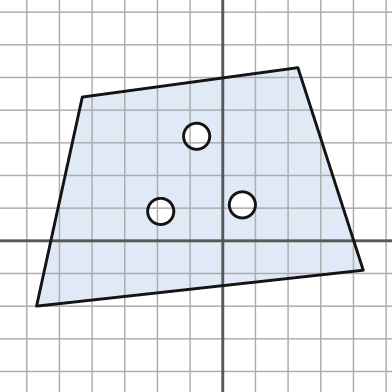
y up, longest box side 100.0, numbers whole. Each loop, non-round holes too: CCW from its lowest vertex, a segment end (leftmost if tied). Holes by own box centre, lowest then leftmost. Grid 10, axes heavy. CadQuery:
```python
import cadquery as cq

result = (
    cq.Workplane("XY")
    .moveTo(-57.0, -20.0)
    .lineTo(43.0, -9.0)
    .lineTo(23.0, 53.0)
    .lineTo(-43.0, 44.0)
    .close()
    .moveTo(-19.0, 9.0)
    .circle(4.0)
    .moveTo(6.0, 11.0)
    .circle(4.0)
    .moveTo(-8.0, 32.0)
    .circle(4.0)
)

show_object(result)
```